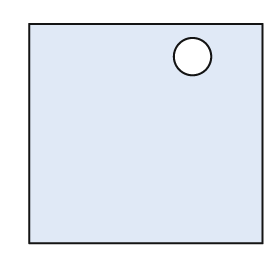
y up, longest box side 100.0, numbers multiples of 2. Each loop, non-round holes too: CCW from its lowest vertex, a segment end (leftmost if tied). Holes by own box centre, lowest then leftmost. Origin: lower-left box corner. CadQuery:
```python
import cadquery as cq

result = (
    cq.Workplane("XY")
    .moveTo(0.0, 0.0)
    .lineTo(100.0, 0.0)
    .lineTo(100.0, 94.0)
    .lineTo(0.0, 94.0)
    .close()
    .moveTo(70.0, 80.0)
    .circle(8.0)
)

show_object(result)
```